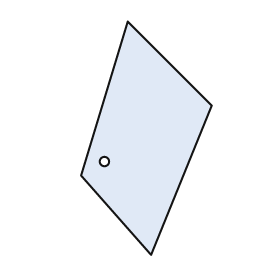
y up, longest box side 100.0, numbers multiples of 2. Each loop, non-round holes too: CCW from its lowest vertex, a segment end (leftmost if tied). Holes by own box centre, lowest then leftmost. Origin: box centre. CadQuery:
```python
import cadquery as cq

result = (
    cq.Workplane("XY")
    .moveTo(2.0, -50.0)
    .lineTo(28.0, 14.0)
    .lineTo(-8.0, 50.0)
    .lineTo(-28.0, -16.0)
    .close()
    .moveTo(-18.0, -10.0)
    .circle(2.0)
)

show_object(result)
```